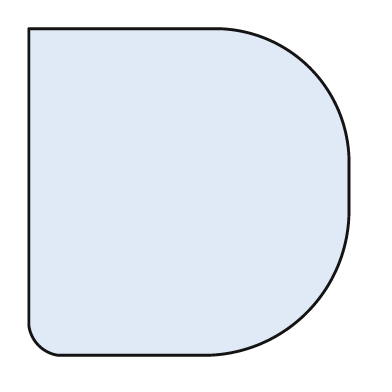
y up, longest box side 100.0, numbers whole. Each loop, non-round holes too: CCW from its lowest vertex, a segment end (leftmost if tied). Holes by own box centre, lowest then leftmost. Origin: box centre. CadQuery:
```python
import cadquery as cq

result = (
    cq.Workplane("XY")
    .moveTo(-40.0, -50.0)
    .lineTo(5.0, -50.0)
    .threePointArc((36.0, -37.0), (49.0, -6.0))
    .lineTo(49.0, 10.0)
    .threePointArc((37.0, 38.0), (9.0, 50.0))
    .lineTo(-49.0, 50.0)
    .lineTo(-49.0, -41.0)
    .threePointArc((-46.0, -47.0), (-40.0, -50.0))
    .close()
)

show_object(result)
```